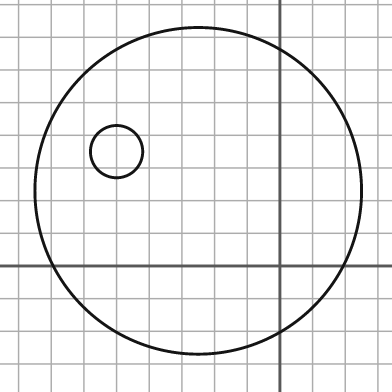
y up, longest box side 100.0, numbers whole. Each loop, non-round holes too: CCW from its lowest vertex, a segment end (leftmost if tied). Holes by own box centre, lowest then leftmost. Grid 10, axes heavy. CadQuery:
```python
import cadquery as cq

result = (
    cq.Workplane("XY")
    .moveTo(-25.0, 23.0)
    .circle(50.0)
    .moveTo(-50.0, 35.0)
    .circle(8.0)
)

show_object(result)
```